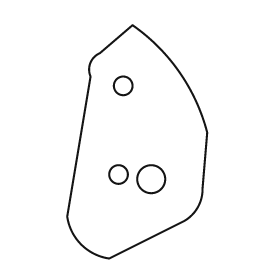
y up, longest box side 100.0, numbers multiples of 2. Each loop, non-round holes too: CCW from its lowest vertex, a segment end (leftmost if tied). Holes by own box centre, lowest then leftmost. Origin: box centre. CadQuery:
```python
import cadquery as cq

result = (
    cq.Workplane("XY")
    .moveTo(-12.0, -50.0)
    .lineTo(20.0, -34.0)
    .threePointArc((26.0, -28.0), (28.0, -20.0))
    .lineTo(30.0, 4.0)
    .threePointArc((18.0, 30.0), (-2.0, 50.0))
    .lineTo(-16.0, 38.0)
    .threePointArc((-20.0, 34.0), (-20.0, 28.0))
    .lineTo(-30.0, -32.0)
    .threePointArc((-24.0, -44.0), (-12.0, -50.0))
    .close()
    .moveTo(6.0, -16.0)
    .circle(6.0)
    .moveTo(-8.0, -14.0)
    .circle(4.0)
    .moveTo(-6.0, 24.0)
    .circle(4.0)
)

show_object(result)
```